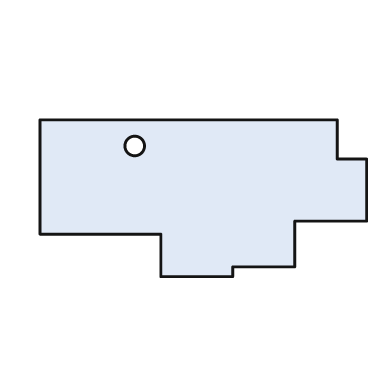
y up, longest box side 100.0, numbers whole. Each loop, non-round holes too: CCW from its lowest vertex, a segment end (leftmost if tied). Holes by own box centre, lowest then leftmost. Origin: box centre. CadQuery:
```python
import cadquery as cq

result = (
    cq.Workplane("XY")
    .moveTo(-13.0, -24.0)
    .lineTo(9.0, -24.0)
    .lineTo(9.0, -21.0)
    .lineTo(28.0, -21.0)
    .lineTo(28.0, -7.0)
    .lineTo(50.0, -7.0)
    .lineTo(50.0, 12.0)
    .lineTo(41.0, 12.0)
    .lineTo(41.0, 24.0)
    .lineTo(-50.0, 24.0)
    .lineTo(-50.0, -11.0)
    .lineTo(-13.0, -11.0)
    .close()
    .moveTo(-21.0, 16.0)
    .circle(3.0)
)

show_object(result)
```